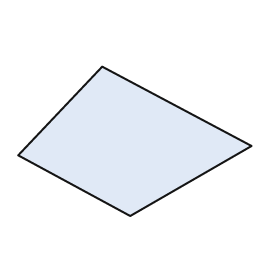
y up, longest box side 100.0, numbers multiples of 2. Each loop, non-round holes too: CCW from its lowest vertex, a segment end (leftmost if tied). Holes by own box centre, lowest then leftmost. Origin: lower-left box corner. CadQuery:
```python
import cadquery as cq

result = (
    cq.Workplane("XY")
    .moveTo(48.0, 0.0)
    .lineTo(100.0, 30.0)
    .lineTo(36.0, 64.0)
    .lineTo(0.0, 26.0)
    .close()
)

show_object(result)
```